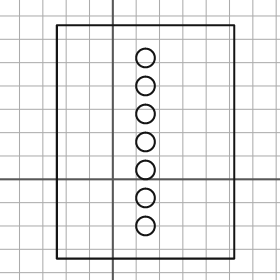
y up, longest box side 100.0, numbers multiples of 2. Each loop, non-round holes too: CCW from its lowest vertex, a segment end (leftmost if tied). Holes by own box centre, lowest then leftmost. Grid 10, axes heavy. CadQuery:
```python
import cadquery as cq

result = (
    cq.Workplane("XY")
    .moveTo(-24.0, -34.0)
    .lineTo(52.0, -34.0)
    .lineTo(52.0, 66.0)
    .lineTo(-24.0, 66.0)
    .close()
    .moveTo(14.0, -20.0)
    .circle(4.0)
    .moveTo(14.0, -8.0)
    .circle(4.0)
    .moveTo(14.0, 4.0)
    .circle(4.0)
    .moveTo(14.0, 16.0)
    .circle(4.0)
    .moveTo(14.0, 28.0)
    .circle(4.0)
    .moveTo(14.0, 40.0)
    .circle(4.0)
    .moveTo(14.0, 52.0)
    .circle(4.0)
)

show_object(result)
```